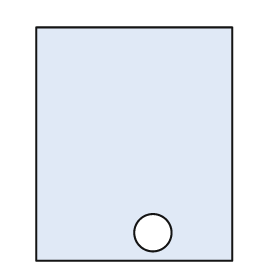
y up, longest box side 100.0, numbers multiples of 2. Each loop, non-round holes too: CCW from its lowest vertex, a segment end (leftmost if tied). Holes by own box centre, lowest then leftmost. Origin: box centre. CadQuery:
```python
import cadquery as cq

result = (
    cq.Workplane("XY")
    .moveTo(-42.0, -50.0)
    .lineTo(42.0, -50.0)
    .lineTo(42.0, 50.0)
    .lineTo(-42.0, 50.0)
    .close()
    .moveTo(8.0, -38.0)
    .circle(8.0)
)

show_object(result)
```